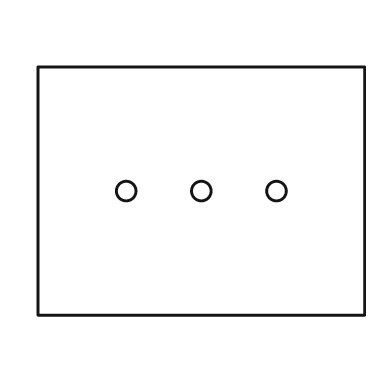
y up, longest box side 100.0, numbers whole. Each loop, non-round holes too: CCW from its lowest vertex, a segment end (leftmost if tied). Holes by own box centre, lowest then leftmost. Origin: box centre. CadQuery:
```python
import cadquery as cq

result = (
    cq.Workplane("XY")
    .moveTo(-50.0, -38.0)
    .lineTo(50.0, -38.0)
    .lineTo(50.0, 38.0)
    .lineTo(-50.0, 38.0)
    .close()
    .moveTo(-23.0, 0.0)
    .circle(3.0)
    .moveTo(0.0, 0.0)
    .circle(3.0)
    .moveTo(23.0, 0.0)
    .circle(3.0)
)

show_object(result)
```